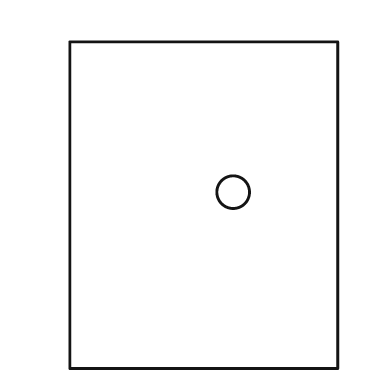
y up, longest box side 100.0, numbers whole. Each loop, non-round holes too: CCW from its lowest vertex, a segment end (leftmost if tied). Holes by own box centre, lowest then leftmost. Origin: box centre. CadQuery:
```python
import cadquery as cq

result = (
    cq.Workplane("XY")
    .moveTo(-41.0, -50.0)
    .lineTo(41.0, -50.0)
    .lineTo(41.0, 50.0)
    .lineTo(-41.0, 50.0)
    .close()
    .moveTo(9.0, 4.0)
    .circle(5.0)
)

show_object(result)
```